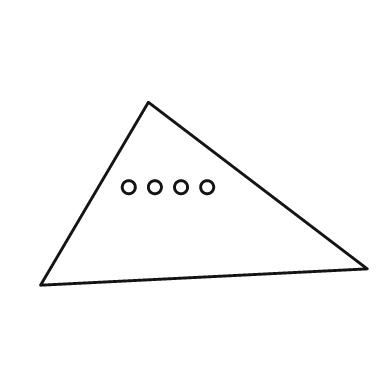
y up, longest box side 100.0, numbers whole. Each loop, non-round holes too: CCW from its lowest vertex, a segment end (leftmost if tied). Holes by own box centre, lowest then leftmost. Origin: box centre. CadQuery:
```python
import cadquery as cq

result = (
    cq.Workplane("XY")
    .moveTo(-50.0, -28.0)
    .lineTo(50.0, -23.0)
    .lineTo(-17.0, 28.0)
    .close()
    .moveTo(-23.0, 2.0)
    .circle(2.0)
    .moveTo(-15.0, 2.0)
    .circle(2.0)
    .moveTo(-7.0, 2.0)
    .circle(2.0)
    .moveTo(1.0, 2.0)
    .circle(2.0)
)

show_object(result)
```